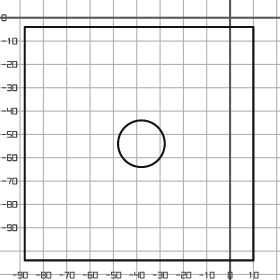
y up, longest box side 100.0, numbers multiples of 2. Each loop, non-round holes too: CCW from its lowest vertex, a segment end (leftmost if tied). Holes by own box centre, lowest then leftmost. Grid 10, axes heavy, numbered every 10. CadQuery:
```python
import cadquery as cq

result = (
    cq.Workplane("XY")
    .moveTo(-88.0, -104.0)
    .lineTo(10.0, -104.0)
    .lineTo(10.0, -4.0)
    .lineTo(-88.0, -4.0)
    .close()
    .moveTo(-38.0, -54.0)
    .circle(10.0)
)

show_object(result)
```